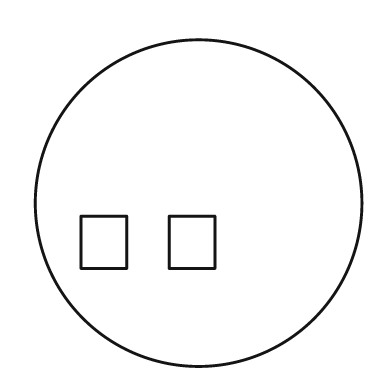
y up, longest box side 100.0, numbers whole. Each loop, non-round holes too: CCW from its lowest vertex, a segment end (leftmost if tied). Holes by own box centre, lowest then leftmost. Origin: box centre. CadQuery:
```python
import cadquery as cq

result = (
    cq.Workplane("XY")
    .moveTo(0.0, 0.0)
    .circle(50.0)
    .moveTo(-36.0, -20.0)
    .lineTo(-22.0, -20.0)
    .lineTo(-22.0, -4.0)
    .lineTo(-36.0, -4.0)
    .close()
    .moveTo(-9.0, -20.0)
    .lineTo(5.0, -20.0)
    .lineTo(5.0, -4.0)
    .lineTo(-9.0, -4.0)
    .close()
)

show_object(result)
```